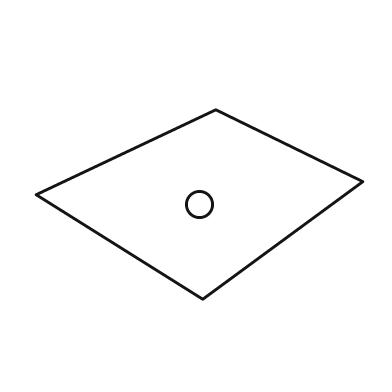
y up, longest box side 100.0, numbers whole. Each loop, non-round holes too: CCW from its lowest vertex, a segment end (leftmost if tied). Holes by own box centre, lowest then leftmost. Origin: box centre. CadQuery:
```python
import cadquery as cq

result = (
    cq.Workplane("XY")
    .moveTo(1.0, -29.0)
    .lineTo(50.0, 7.0)
    .lineTo(5.0, 29.0)
    .lineTo(-50.0, 3.0)
    .close()
    .moveTo(0.0, 0.0)
    .circle(4.0)
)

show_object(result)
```